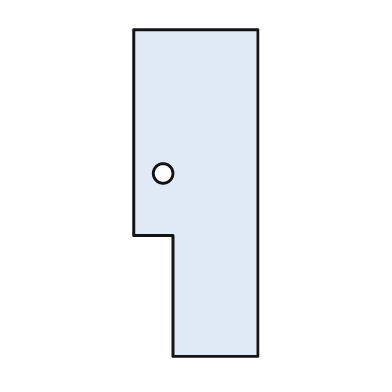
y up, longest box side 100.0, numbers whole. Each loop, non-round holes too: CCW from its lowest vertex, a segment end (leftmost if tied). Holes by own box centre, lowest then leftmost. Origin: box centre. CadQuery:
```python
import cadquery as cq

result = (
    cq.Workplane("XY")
    .moveTo(-7.0, -50.0)
    .lineTo(19.0, -50.0)
    .lineTo(19.0, 50.0)
    .lineTo(-19.0, 50.0)
    .lineTo(-19.0, -13.0)
    .lineTo(-7.0, -13.0)
    .close()
    .moveTo(-10.0, 6.0)
    .circle(3.0)
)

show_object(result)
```